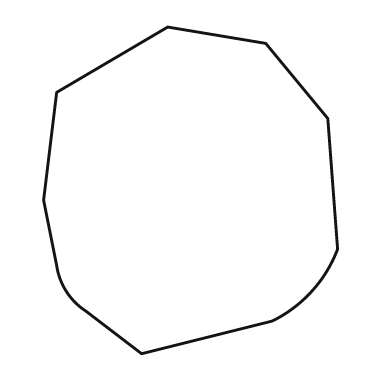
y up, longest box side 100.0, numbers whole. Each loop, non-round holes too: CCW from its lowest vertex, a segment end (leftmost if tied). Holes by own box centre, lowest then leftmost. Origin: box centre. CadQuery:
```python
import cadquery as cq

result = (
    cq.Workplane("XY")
    .moveTo(-15.0, -50.0)
    .lineTo(25.0, -40.0)
    .threePointArc((37.0, -31.0), (45.0, -18.0))
    .lineTo(42.0, 22.0)
    .lineTo(23.0, 45.0)
    .lineTo(-7.0, 50.0)
    .lineTo(-41.0, 30.0)
    .lineTo(-45.0, -3.0)
    .lineTo(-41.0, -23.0)
    .threePointArc((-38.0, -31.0), (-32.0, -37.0))
    .close()
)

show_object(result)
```